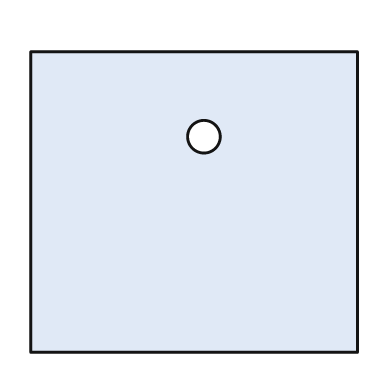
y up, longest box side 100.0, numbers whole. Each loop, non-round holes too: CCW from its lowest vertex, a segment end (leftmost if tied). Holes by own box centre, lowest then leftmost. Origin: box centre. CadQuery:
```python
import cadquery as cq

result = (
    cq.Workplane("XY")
    .moveTo(-50.0, -46.0)
    .lineTo(50.0, -46.0)
    .lineTo(50.0, 46.0)
    .lineTo(-50.0, 46.0)
    .close()
    .moveTo(3.0, 20.0)
    .circle(5.0)
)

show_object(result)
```